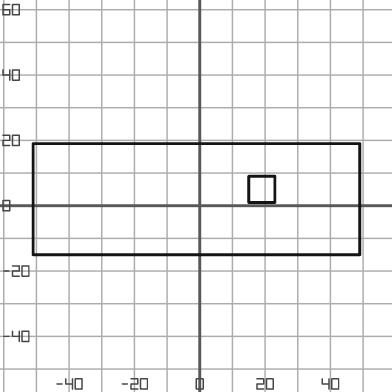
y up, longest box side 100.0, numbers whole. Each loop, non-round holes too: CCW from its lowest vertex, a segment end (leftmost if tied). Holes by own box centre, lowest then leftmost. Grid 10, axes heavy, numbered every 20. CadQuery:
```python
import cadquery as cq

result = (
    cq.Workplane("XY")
    .moveTo(-51.0, -15.0)
    .lineTo(49.0, -15.0)
    .lineTo(49.0, 19.0)
    .lineTo(-51.0, 19.0)
    .close()
    .moveTo(15.0, 1.0)
    .lineTo(23.0, 1.0)
    .lineTo(23.0, 9.0)
    .lineTo(15.0, 9.0)
    .close()
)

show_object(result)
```